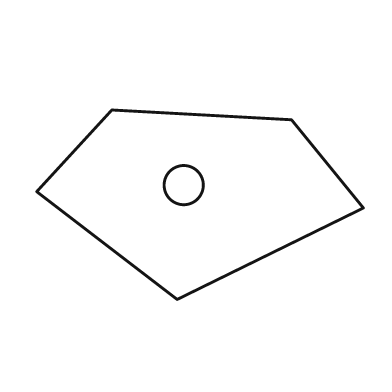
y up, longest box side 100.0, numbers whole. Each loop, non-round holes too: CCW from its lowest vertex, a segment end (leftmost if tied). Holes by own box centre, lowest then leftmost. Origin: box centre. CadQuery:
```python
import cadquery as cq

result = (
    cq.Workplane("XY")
    .moveTo(-7.0, -29.0)
    .lineTo(50.0, -1.0)
    .lineTo(28.0, 26.0)
    .lineTo(-27.0, 29.0)
    .lineTo(-50.0, 4.0)
    .close()
    .moveTo(-5.0, 6.0)
    .circle(6.0)
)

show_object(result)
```